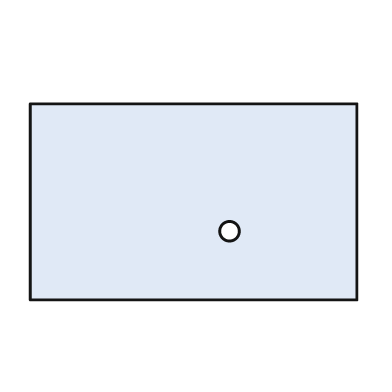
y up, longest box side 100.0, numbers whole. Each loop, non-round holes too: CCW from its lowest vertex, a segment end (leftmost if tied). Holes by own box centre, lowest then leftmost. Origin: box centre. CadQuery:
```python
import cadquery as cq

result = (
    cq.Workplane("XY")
    .moveTo(-50.0, -30.0)
    .lineTo(50.0, -30.0)
    .lineTo(50.0, 30.0)
    .lineTo(-50.0, 30.0)
    .close()
    .moveTo(11.0, -9.0)
    .circle(3.0)
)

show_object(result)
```